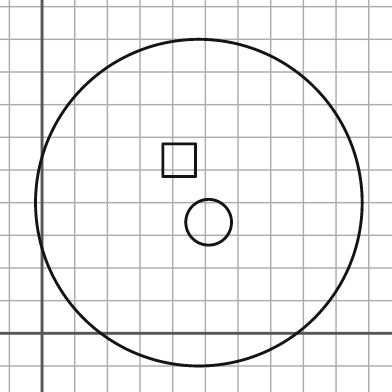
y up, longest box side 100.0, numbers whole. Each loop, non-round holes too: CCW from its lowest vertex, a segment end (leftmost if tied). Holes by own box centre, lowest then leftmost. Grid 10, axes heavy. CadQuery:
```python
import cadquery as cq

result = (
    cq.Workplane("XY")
    .moveTo(48.0, 40.0)
    .circle(50.0)
    .moveTo(51.0, 34.0)
    .circle(7.0)
    .moveTo(37.0, 48.0)
    .lineTo(47.0, 48.0)
    .lineTo(47.0, 58.0)
    .lineTo(37.0, 58.0)
    .close()
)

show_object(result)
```